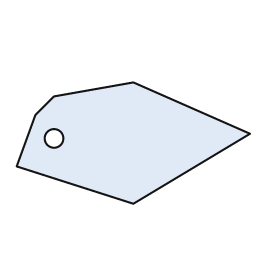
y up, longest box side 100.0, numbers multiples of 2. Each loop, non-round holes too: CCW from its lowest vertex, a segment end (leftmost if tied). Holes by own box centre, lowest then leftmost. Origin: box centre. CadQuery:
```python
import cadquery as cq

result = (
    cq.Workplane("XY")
    .moveTo(0.0, -26.0)
    .lineTo(50.0, 4.0)
    .lineTo(0.0, 26.0)
    .lineTo(-34.0, 20.0)
    .lineTo(-42.0, 12.0)
    .lineTo(-50.0, -10.0)
    .close()
    .moveTo(-34.0, 2.0)
    .circle(4.0)
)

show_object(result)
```